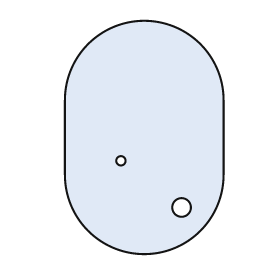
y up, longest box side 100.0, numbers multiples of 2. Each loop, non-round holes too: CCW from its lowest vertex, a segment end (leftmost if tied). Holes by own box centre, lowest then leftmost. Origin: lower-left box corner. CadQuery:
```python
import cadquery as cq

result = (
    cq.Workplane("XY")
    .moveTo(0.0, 34.0)
    .threePointArc((34.0, 0.0), (68.0, 34.0))
    .lineTo(68.0, 66.0)
    .threePointArc((34.0, 100.0), (0.0, 66.0))
    .close()
    .moveTo(50.0, 20.0)
    .circle(4.0)
    .moveTo(24.0, 40.0)
    .circle(2.0)
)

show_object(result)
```